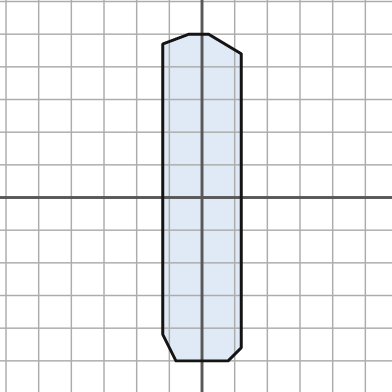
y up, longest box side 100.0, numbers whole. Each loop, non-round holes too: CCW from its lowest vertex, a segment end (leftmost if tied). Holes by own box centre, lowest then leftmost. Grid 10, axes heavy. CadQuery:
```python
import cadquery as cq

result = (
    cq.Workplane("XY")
    .moveTo(-8.0, -50.0)
    .lineTo(8.0, -50.0)
    .lineTo(12.0, -46.0)
    .lineTo(12.0, 44.0)
    .lineTo(2.0, 50.0)
    .lineTo(-4.0, 50.0)
    .lineTo(-12.0, 47.0)
    .lineTo(-12.0, -42.0)
    .close()
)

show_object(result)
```